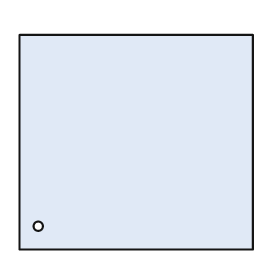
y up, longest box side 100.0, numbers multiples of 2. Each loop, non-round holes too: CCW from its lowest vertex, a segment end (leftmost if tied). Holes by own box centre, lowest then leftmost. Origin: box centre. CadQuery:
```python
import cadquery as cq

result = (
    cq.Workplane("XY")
    .moveTo(-50.0, -46.0)
    .lineTo(50.0, -46.0)
    .lineTo(50.0, 46.0)
    .lineTo(-50.0, 46.0)
    .close()
    .moveTo(-42.0, -36.0)
    .circle(2.0)
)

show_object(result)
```